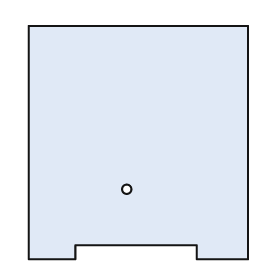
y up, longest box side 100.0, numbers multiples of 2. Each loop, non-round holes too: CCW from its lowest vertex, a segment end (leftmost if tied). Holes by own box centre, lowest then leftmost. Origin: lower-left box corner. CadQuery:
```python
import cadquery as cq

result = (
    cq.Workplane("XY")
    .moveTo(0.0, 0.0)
    .lineTo(20.0, 0.0)
    .lineTo(20.0, 6.0)
    .lineTo(72.0, 6.0)
    .lineTo(72.0, 0.0)
    .lineTo(94.0, 0.0)
    .lineTo(94.0, 100.0)
    .lineTo(0.0, 100.0)
    .close()
    .moveTo(42.0, 30.0)
    .circle(2.0)
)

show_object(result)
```